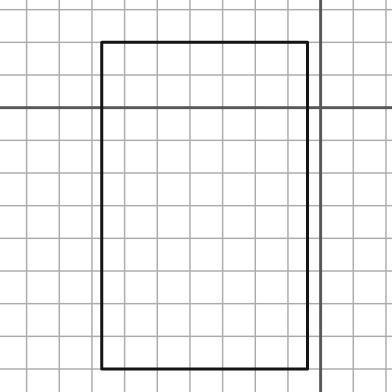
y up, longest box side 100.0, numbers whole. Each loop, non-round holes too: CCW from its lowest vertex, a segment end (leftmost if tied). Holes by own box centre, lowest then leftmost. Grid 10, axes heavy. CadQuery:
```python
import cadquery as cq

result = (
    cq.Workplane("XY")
    .moveTo(-67.0, -80.0)
    .lineTo(-4.0, -80.0)
    .lineTo(-4.0, 20.0)
    .lineTo(-67.0, 20.0)
    .close()
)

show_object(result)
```